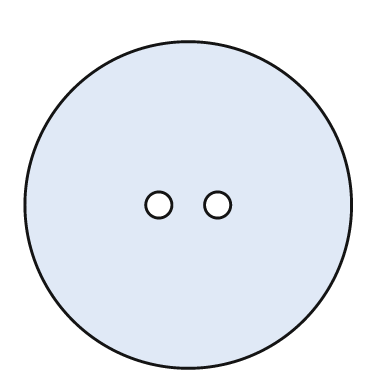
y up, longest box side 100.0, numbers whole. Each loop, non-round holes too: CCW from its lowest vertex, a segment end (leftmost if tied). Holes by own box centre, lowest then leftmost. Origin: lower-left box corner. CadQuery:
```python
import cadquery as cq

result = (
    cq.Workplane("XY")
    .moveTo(50.0, 50.0)
    .circle(50.0)
    .moveTo(41.0, 50.0)
    .circle(4.0)
    .moveTo(59.0, 50.0)
    .circle(4.0)
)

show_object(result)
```